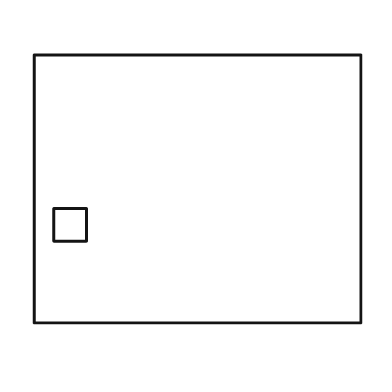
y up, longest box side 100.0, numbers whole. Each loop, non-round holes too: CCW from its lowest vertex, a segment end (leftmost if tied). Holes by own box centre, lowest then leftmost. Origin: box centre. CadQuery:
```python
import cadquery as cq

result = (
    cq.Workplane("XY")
    .moveTo(-50.0, -41.0)
    .lineTo(50.0, -41.0)
    .lineTo(50.0, 41.0)
    .lineTo(-50.0, 41.0)
    .close()
    .moveTo(-44.0, -16.0)
    .lineTo(-34.0, -16.0)
    .lineTo(-34.0, -6.0)
    .lineTo(-44.0, -6.0)
    .close()
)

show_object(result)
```